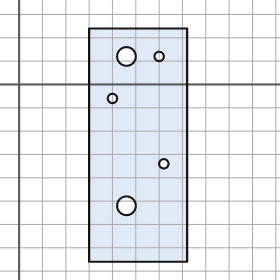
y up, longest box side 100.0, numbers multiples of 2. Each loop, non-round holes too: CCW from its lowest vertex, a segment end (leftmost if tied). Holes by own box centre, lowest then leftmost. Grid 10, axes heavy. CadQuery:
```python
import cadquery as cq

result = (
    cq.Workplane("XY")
    .moveTo(30.0, -76.0)
    .lineTo(72.0, -76.0)
    .lineTo(72.0, 24.0)
    .lineTo(30.0, 24.0)
    .close()
    .moveTo(46.0, -52.0)
    .circle(4.0)
    .moveTo(62.0, -34.0)
    .circle(2.0)
    .moveTo(40.0, -6.0)
    .circle(2.0)
    .moveTo(46.0, 12.0)
    .circle(4.0)
    .moveTo(60.0, 12.0)
    .circle(2.0)
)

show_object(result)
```